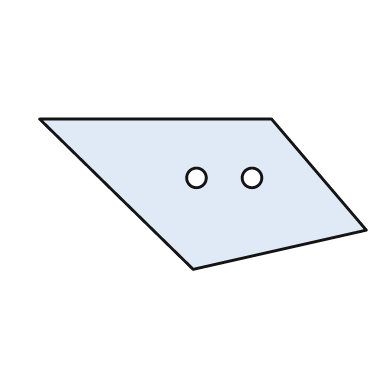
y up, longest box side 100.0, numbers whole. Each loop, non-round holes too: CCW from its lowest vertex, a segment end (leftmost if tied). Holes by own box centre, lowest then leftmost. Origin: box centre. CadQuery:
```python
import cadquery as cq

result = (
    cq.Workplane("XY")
    .moveTo(-3.0, -23.0)
    .lineTo(50.0, -11.0)
    .lineTo(21.0, 23.0)
    .lineTo(-50.0, 23.0)
    .close()
    .moveTo(-2.0, 5.0)
    .circle(3.0)
    .moveTo(15.0, 5.0)
    .circle(3.0)
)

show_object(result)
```